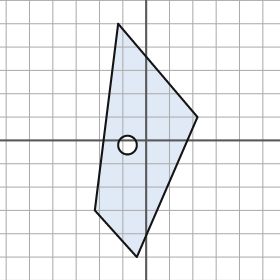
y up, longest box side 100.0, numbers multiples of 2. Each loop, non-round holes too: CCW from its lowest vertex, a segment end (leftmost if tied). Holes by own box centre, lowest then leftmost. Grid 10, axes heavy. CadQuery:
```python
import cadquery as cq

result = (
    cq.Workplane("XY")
    .moveTo(-4.0, -50.0)
    .lineTo(22.0, 10.0)
    .lineTo(-12.0, 50.0)
    .lineTo(-22.0, -30.0)
    .close()
    .moveTo(-8.0, -2.0)
    .circle(4.0)
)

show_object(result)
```